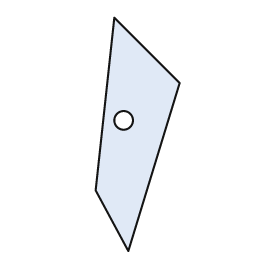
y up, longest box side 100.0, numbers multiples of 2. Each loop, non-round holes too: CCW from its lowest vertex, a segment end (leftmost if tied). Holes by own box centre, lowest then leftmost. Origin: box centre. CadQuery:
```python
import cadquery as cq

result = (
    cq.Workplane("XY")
    .moveTo(-4.0, -50.0)
    .lineTo(18.0, 22.0)
    .lineTo(-10.0, 50.0)
    .lineTo(-18.0, -24.0)
    .close()
    .moveTo(-6.0, 6.0)
    .circle(4.0)
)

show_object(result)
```